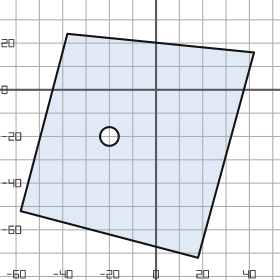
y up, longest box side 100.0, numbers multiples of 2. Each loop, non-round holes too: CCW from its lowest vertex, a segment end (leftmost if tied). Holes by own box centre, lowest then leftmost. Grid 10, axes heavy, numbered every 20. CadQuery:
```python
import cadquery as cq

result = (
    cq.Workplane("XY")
    .moveTo(18.0, -72.0)
    .lineTo(42.0, 16.0)
    .lineTo(-38.0, 24.0)
    .lineTo(-58.0, -52.0)
    .close()
    .moveTo(-20.0, -20.0)
    .circle(4.0)
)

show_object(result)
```